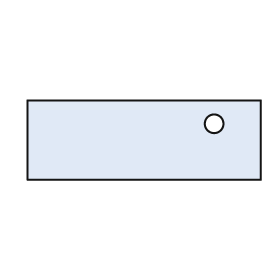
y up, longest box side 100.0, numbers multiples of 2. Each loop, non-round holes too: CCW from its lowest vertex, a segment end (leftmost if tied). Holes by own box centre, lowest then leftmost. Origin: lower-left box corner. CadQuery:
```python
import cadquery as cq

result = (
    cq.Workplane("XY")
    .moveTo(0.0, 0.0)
    .lineTo(100.0, 0.0)
    .lineTo(100.0, 34.0)
    .lineTo(0.0, 34.0)
    .close()
    .moveTo(80.0, 24.0)
    .circle(4.0)
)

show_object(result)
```